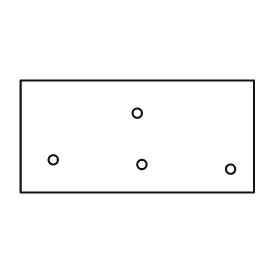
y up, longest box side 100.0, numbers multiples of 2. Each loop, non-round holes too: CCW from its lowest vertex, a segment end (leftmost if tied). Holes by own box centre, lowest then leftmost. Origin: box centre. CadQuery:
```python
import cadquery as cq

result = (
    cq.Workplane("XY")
    .moveTo(-50.0, -24.0)
    .lineTo(50.0, -24.0)
    .lineTo(50.0, 24.0)
    .lineTo(-50.0, 24.0)
    .close()
    .moveTo(40.0, -14.0)
    .circle(2.0)
    .moveTo(2.0, -12.0)
    .circle(2.0)
    .moveTo(-36.0, -10.0)
    .circle(2.0)
    .moveTo(0.0, 10.0)
    .circle(2.0)
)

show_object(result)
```